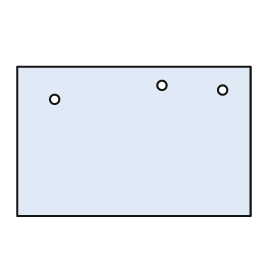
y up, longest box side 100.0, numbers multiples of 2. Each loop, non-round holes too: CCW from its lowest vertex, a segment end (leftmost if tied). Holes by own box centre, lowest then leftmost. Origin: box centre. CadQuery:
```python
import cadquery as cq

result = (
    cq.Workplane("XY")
    .moveTo(-50.0, -32.0)
    .lineTo(50.0, -32.0)
    .lineTo(50.0, 32.0)
    .lineTo(-50.0, 32.0)
    .close()
    .moveTo(-34.0, 18.0)
    .circle(2.0)
    .moveTo(38.0, 22.0)
    .circle(2.0)
    .moveTo(12.0, 24.0)
    .circle(2.0)
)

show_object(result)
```